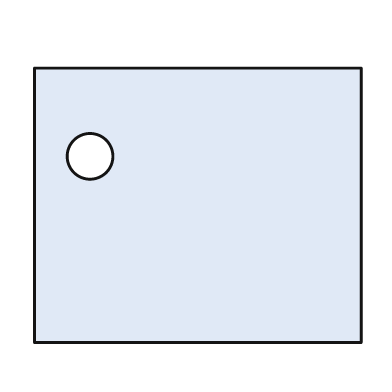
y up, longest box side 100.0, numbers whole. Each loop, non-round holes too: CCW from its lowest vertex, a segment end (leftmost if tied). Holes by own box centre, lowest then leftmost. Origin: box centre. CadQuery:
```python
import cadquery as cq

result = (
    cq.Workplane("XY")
    .moveTo(-50.0, -42.0)
    .lineTo(50.0, -42.0)
    .lineTo(50.0, 42.0)
    .lineTo(-50.0, 42.0)
    .close()
    .moveTo(-33.0, 15.0)
    .circle(7.0)
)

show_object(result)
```